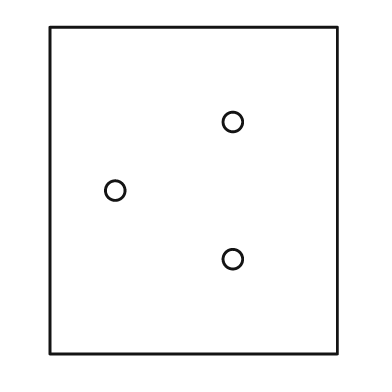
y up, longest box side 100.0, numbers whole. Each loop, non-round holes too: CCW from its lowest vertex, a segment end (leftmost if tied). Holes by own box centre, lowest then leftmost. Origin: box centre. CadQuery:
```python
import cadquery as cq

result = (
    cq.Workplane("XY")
    .moveTo(-44.0, -50.0)
    .lineTo(44.0, -50.0)
    .lineTo(44.0, 50.0)
    .lineTo(-44.0, 50.0)
    .close()
    .moveTo(12.0, -21.0)
    .circle(3.0)
    .moveTo(-24.0, 0.0)
    .circle(3.0)
    .moveTo(12.0, 21.0)
    .circle(3.0)
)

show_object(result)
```